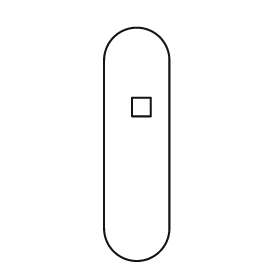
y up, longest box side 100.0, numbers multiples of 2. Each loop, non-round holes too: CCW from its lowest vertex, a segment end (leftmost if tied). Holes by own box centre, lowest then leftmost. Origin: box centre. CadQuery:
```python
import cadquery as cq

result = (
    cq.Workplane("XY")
    .moveTo(-14.0, -36.0)
    .threePointArc((0.0, -50.0), (14.0, -36.0))
    .lineTo(14.0, 36.0)
    .threePointArc((0.0, 50.0), (-14.0, 36.0))
    .close()
    .moveTo(-2.0, 12.0)
    .lineTo(6.0, 12.0)
    .lineTo(6.0, 20.0)
    .lineTo(-2.0, 20.0)
    .close()
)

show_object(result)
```